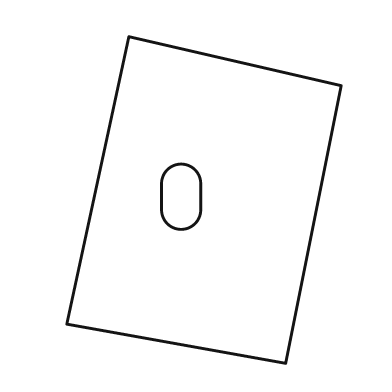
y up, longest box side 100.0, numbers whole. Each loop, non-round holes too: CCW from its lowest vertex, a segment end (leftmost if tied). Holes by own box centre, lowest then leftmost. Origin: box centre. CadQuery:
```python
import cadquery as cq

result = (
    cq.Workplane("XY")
    .moveTo(25.0, -50.0)
    .lineTo(42.0, 35.0)
    .lineTo(-23.0, 50.0)
    .lineTo(-42.0, -38.0)
    .close()
    .moveTo(-13.0, -3.0)
    .threePointArc((-7.0, -9.0), (-1.0, -3.0))
    .lineTo(-1.0, 5.0)
    .threePointArc((-7.0, 11.0), (-13.0, 5.0))
    .close()
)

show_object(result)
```